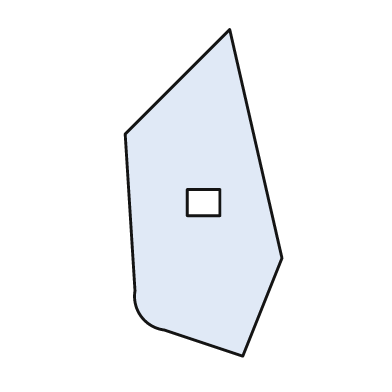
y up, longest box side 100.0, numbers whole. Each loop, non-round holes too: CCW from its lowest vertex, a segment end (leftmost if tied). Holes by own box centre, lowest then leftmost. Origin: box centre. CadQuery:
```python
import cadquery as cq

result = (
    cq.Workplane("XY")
    .moveTo(12.0, -50.0)
    .lineTo(24.0, -20.0)
    .lineTo(8.0, 50.0)
    .lineTo(-24.0, 18.0)
    .lineTo(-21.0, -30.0)
    .threePointArc((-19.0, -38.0), (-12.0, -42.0))
    .close()
    .moveTo(-5.0, -7.0)
    .lineTo(5.0, -7.0)
    .lineTo(5.0, 1.0)
    .lineTo(-5.0, 1.0)
    .close()
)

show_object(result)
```